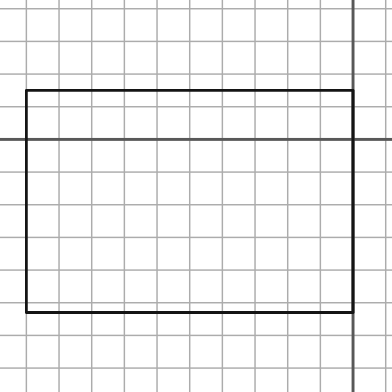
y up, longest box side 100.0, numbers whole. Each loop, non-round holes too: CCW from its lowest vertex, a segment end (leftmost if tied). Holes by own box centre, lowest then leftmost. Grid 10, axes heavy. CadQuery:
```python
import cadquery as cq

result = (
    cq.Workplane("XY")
    .moveTo(-100.0, -53.0)
    .lineTo(0.0, -53.0)
    .lineTo(0.0, 15.0)
    .lineTo(-100.0, 15.0)
    .close()
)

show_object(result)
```